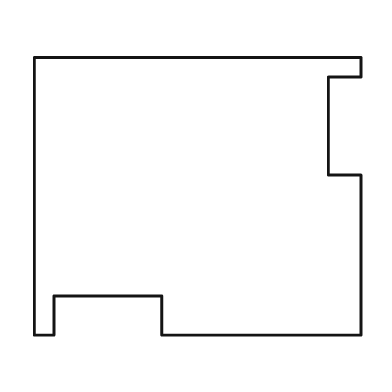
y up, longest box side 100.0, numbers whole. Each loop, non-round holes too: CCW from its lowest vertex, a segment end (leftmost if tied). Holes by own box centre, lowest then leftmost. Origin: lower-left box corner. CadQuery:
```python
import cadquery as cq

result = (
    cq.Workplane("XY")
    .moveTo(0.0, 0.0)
    .lineTo(6.0, 0.0)
    .lineTo(6.0, 12.0)
    .lineTo(39.0, 12.0)
    .lineTo(39.0, 0.0)
    .lineTo(100.0, 0.0)
    .lineTo(100.0, 49.0)
    .lineTo(90.0, 49.0)
    .lineTo(90.0, 79.0)
    .lineTo(100.0, 79.0)
    .lineTo(100.0, 85.0)
    .lineTo(0.0, 85.0)
    .close()
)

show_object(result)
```